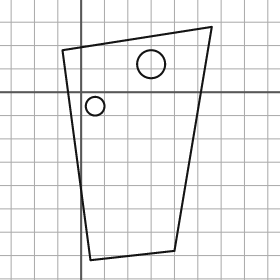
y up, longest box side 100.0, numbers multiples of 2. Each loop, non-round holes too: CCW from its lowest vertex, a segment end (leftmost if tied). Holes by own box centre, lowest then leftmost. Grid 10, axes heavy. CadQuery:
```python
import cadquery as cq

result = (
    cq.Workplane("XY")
    .moveTo(4.0, -72.0)
    .lineTo(40.0, -68.0)
    .lineTo(56.0, 28.0)
    .lineTo(-8.0, 18.0)
    .close()
    .moveTo(6.0, -6.0)
    .circle(4.0)
    .moveTo(30.0, 12.0)
    .circle(6.0)
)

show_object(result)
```